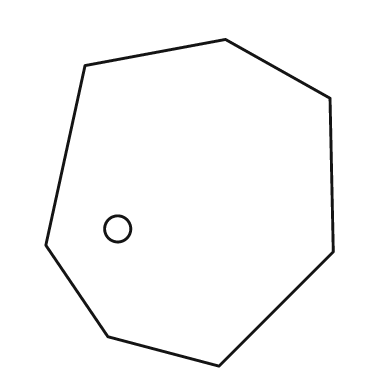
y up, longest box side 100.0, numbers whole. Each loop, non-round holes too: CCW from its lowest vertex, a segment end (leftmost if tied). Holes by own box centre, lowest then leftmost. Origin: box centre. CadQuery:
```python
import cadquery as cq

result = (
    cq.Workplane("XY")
    .moveTo(9.0, -50.0)
    .lineTo(44.0, -15.0)
    .lineTo(43.0, 32.0)
    .lineTo(11.0, 50.0)
    .lineTo(-32.0, 42.0)
    .lineTo(-44.0, -13.0)
    .lineTo(-25.0, -41.0)
    .close()
    .moveTo(-22.0, -8.0)
    .circle(4.0)
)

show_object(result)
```